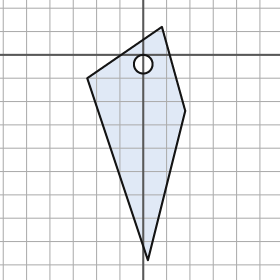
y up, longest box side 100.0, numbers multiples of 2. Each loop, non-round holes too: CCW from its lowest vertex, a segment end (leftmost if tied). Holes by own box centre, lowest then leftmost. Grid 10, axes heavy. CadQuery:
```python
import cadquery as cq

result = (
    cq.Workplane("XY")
    .moveTo(2.0, -88.0)
    .lineTo(18.0, -24.0)
    .lineTo(8.0, 12.0)
    .lineTo(-24.0, -10.0)
    .close()
    .moveTo(0.0, -4.0)
    .circle(4.0)
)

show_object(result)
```